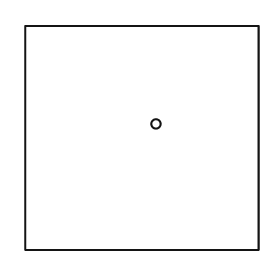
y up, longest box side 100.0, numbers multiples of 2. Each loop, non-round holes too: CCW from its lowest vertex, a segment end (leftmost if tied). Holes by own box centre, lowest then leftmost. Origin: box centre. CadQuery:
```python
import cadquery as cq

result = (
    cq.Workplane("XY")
    .moveTo(-50.0, -48.0)
    .lineTo(50.0, -48.0)
    .lineTo(50.0, 48.0)
    .lineTo(-50.0, 48.0)
    .close()
    .moveTo(6.0, 6.0)
    .circle(2.0)
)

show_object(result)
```